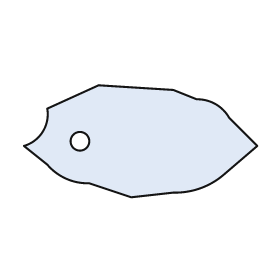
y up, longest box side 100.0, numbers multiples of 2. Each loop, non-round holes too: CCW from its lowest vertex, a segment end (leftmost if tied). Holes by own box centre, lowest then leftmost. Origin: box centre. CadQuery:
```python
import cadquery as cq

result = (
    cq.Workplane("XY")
    .moveTo(-4.0, -24.0)
    .lineTo(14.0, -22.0)
    .threePointArc((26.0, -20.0), (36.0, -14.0))
    .lineTo(50.0, -2.0)
    .lineTo(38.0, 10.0)
    .threePointArc((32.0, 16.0), (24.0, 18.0))
    .lineTo(14.0, 22.0)
    .lineTo(-18.0, 24.0)
    .lineTo(-40.0, 14.0)
    .threePointArc((-42.0, 4.0), (-50.0, -2.0))
    .lineTo(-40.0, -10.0)
    .threePointArc((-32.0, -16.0), (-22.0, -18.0))
    .close()
    .moveTo(-26.0, 0.0)
    .circle(4.0)
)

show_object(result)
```